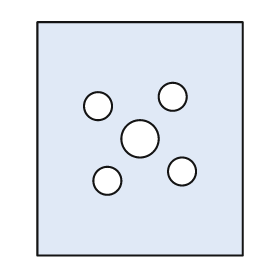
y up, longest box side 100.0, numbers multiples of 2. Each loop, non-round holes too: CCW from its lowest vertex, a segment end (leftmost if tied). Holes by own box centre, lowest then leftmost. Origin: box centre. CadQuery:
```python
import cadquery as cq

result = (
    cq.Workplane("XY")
    .moveTo(-44.0, -50.0)
    .lineTo(44.0, -50.0)
    .lineTo(44.0, 50.0)
    .lineTo(-44.0, 50.0)
    .close()
    .moveTo(-14.0, -18.0)
    .circle(6.0)
    .moveTo(18.0, -14.0)
    .circle(6.0)
    .moveTo(0.0, 0.0)
    .circle(8.0)
    .moveTo(-18.0, 14.0)
    .circle(6.0)
    .moveTo(14.0, 18.0)
    .circle(6.0)
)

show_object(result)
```